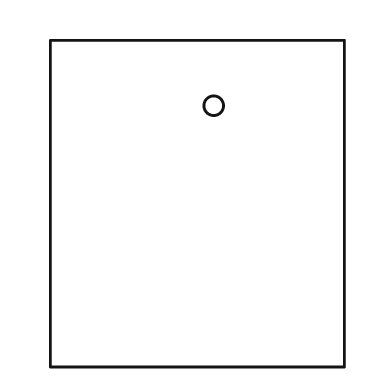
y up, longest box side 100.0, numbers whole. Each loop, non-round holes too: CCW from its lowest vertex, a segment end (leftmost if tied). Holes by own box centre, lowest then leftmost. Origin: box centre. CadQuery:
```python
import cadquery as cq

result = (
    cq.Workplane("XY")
    .moveTo(-45.0, -50.0)
    .lineTo(45.0, -50.0)
    .lineTo(45.0, 50.0)
    .lineTo(-45.0, 50.0)
    .close()
    .moveTo(5.0, 30.0)
    .circle(3.0)
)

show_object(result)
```